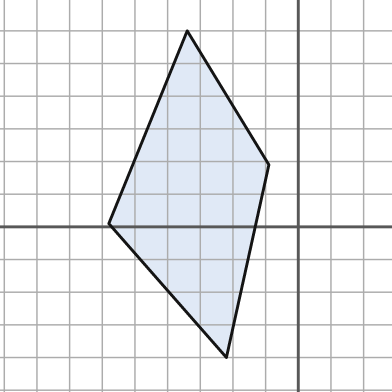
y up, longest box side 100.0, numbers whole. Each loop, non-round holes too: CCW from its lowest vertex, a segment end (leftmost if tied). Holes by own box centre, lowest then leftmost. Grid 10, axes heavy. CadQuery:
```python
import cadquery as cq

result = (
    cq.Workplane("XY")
    .moveTo(-22.0, -40.0)
    .lineTo(-9.0, 19.0)
    .lineTo(-34.0, 60.0)
    .lineTo(-58.0, 1.0)
    .close()
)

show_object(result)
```